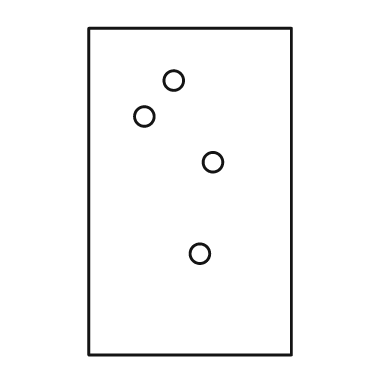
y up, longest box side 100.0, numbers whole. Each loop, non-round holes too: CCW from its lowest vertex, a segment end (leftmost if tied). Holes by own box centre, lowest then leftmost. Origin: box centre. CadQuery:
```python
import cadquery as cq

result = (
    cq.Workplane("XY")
    .moveTo(-31.0, -50.0)
    .lineTo(31.0, -50.0)
    .lineTo(31.0, 50.0)
    .lineTo(-31.0, 50.0)
    .close()
    .moveTo(3.0, -19.0)
    .circle(3.0)
    .moveTo(7.0, 9.0)
    .circle(3.0)
    .moveTo(-14.0, 23.0)
    .circle(3.0)
    .moveTo(-5.0, 34.0)
    .circle(3.0)
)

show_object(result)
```